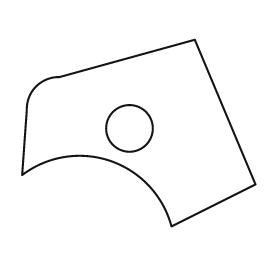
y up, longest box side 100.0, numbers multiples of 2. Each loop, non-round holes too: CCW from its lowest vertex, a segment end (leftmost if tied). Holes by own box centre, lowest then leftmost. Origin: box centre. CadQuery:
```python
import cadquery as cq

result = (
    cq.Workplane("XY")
    .moveTo(14.0, -40.0)
    .lineTo(50.0, -22.0)
    .lineTo(24.0, 40.0)
    .lineTo(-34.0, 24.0)
    .threePointArc((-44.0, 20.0), (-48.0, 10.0))
    .lineTo(-50.0, -18.0)
    .threePointArc((-12.0, -12.0), (14.0, -40.0))
    .close()
    .moveTo(-4.0, 2.0)
    .circle(10.0)
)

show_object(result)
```